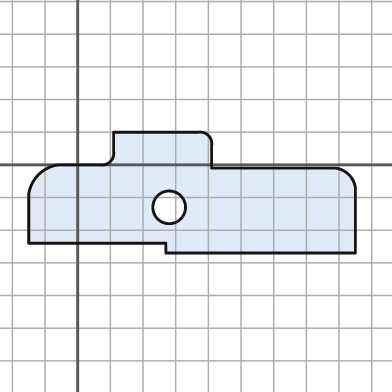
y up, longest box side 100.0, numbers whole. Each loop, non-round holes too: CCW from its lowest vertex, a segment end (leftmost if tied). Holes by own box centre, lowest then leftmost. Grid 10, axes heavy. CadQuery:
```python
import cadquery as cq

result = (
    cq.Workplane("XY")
    .moveTo(27.0, -27.0)
    .lineTo(85.0, -27.0)
    .lineTo(85.0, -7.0)
    .threePointArc((83.0, -3.0), (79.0, -1.0))
    .lineTo(41.0, -1.0)
    .lineTo(41.0, 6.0)
    .threePointArc((40.0, 9.0), (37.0, 10.0))
    .lineTo(11.0, 10.0)
    .lineTo(11.0, 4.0)
    .threePointArc((10.0, 1.0), (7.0, 0.0))
    .lineTo(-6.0, 0.0)
    .threePointArc((-12.0, -3.0), (-15.0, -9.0))
    .lineTo(-15.0, -24.0)
    .lineTo(27.0, -24.0)
    .close()
    .moveTo(28.0, -13.0)
    .circle(5.0)
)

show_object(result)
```